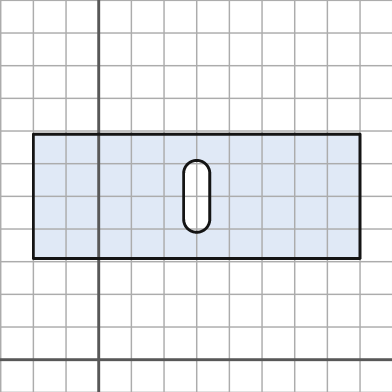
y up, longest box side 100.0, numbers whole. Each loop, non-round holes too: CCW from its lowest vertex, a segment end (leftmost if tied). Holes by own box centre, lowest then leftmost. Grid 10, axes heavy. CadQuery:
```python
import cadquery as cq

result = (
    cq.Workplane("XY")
    .moveTo(-20.0, 31.0)
    .lineTo(80.0, 31.0)
    .lineTo(80.0, 69.0)
    .lineTo(-20.0, 69.0)
    .close()
    .moveTo(26.0, 43.0)
    .threePointArc((30.0, 39.0), (34.0, 43.0))
    .lineTo(34.0, 57.0)
    .threePointArc((30.0, 61.0), (26.0, 57.0))
    .close()
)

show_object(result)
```